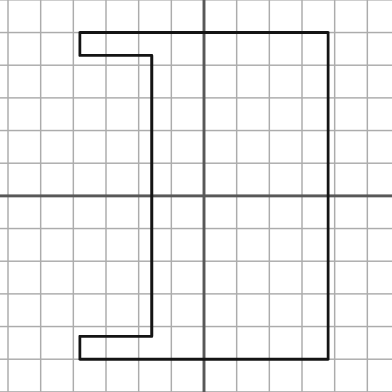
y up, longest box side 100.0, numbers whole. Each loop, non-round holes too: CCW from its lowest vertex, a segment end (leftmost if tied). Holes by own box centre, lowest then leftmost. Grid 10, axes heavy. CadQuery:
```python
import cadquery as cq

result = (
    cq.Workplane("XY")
    .moveTo(-38.0, -50.0)
    .lineTo(38.0, -50.0)
    .lineTo(38.0, 50.0)
    .lineTo(-38.0, 50.0)
    .lineTo(-38.0, 43.0)
    .lineTo(-16.0, 43.0)
    .lineTo(-16.0, -43.0)
    .lineTo(-38.0, -43.0)
    .close()
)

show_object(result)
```